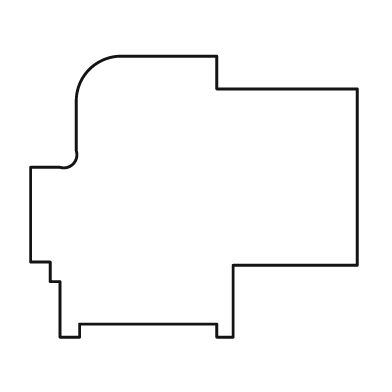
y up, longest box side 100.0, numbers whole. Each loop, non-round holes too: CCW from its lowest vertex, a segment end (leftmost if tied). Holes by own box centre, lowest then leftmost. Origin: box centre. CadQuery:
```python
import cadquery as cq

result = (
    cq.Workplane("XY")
    .moveTo(-41.0, -43.0)
    .lineTo(-35.0, -43.0)
    .lineTo(-35.0, -39.0)
    .lineTo(7.0, -39.0)
    .lineTo(7.0, -43.0)
    .lineTo(12.0, -43.0)
    .lineTo(12.0, -21.0)
    .lineTo(50.0, -21.0)
    .lineTo(50.0, 33.0)
    .lineTo(7.0, 33.0)
    .lineTo(7.0, 43.0)
    .lineTo(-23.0, 43.0)
    .threePointArc((-32.0, 39.0), (-36.0, 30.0))
    .lineTo(-36.0, 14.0)
    .threePointArc((-37.0, 10.0), (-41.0, 9.0))
    .lineTo(-50.0, 9.0)
    .lineTo(-50.0, -20.0)
    .lineTo(-44.0, -20.0)
    .lineTo(-44.0, -26.0)
    .lineTo(-41.0, -26.0)
    .close()
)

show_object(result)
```